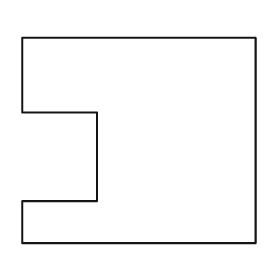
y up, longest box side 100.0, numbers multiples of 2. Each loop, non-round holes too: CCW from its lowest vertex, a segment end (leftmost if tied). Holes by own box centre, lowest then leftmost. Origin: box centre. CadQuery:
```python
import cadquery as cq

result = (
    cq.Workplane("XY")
    .moveTo(-50.0, -44.0)
    .lineTo(50.0, -44.0)
    .lineTo(50.0, 44.0)
    .lineTo(-50.0, 44.0)
    .lineTo(-50.0, 12.0)
    .lineTo(-18.0, 12.0)
    .lineTo(-18.0, -26.0)
    .lineTo(-50.0, -26.0)
    .close()
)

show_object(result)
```